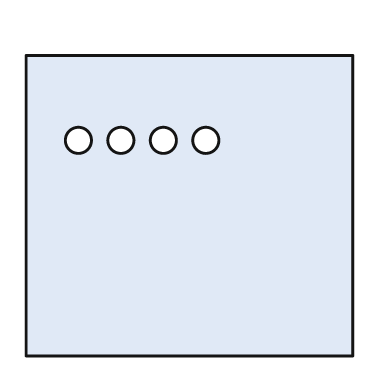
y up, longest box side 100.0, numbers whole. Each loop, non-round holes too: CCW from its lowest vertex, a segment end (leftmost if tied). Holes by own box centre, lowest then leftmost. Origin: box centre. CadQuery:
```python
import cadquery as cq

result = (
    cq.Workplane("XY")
    .moveTo(-50.0, -46.0)
    .lineTo(50.0, -46.0)
    .lineTo(50.0, 46.0)
    .lineTo(-50.0, 46.0)
    .close()
    .moveTo(-34.0, 20.0)
    .circle(4.0)
    .moveTo(-21.0, 20.0)
    .circle(4.0)
    .moveTo(-8.0, 20.0)
    .circle(4.0)
    .moveTo(5.0, 20.0)
    .circle(4.0)
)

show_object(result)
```